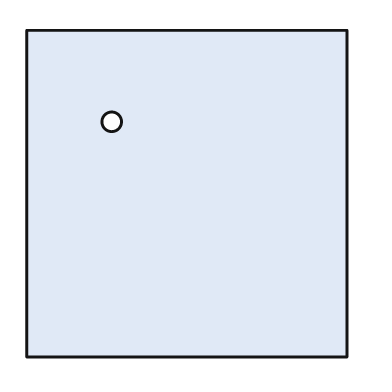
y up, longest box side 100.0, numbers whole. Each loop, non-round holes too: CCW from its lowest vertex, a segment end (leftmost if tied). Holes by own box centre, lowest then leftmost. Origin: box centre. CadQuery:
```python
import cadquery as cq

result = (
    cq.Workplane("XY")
    .moveTo(-49.0, -50.0)
    .lineTo(49.0, -50.0)
    .lineTo(49.0, 50.0)
    .lineTo(-49.0, 50.0)
    .close()
    .moveTo(-23.0, 22.0)
    .circle(3.0)
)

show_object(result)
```